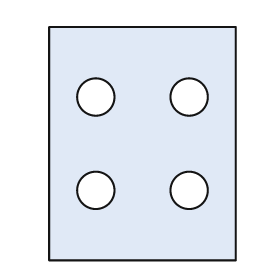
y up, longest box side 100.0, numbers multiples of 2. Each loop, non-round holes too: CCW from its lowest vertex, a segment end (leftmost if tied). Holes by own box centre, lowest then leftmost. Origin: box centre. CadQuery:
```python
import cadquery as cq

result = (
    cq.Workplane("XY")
    .moveTo(-40.0, -50.0)
    .lineTo(40.0, -50.0)
    .lineTo(40.0, 50.0)
    .lineTo(-40.0, 50.0)
    .close()
    .moveTo(-20.0, -20.0)
    .circle(8.0)
    .moveTo(20.0, -20.0)
    .circle(8.0)
    .moveTo(-20.0, 20.0)
    .circle(8.0)
    .moveTo(20.0, 20.0)
    .circle(8.0)
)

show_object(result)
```